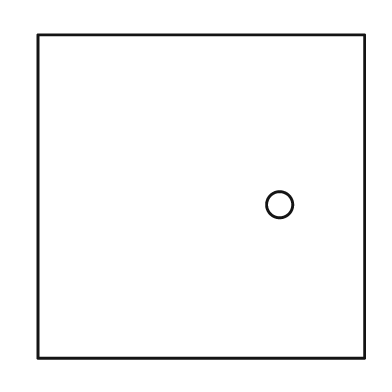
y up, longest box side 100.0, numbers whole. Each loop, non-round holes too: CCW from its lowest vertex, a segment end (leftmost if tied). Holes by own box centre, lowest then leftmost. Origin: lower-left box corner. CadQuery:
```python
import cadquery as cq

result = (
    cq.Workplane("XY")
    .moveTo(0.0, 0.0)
    .lineTo(100.0, 0.0)
    .lineTo(100.0, 99.0)
    .lineTo(0.0, 99.0)
    .close()
    .moveTo(74.0, 47.0)
    .circle(4.0)
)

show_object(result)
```